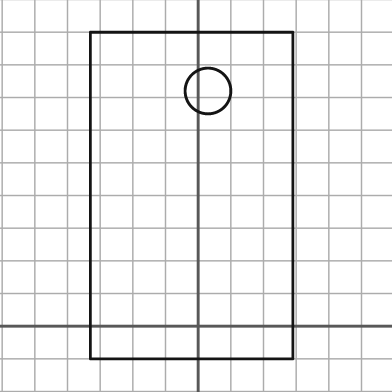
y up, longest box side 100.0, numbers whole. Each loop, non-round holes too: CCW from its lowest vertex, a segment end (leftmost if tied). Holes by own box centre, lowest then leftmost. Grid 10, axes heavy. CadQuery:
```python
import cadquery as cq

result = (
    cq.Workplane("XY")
    .moveTo(-33.0, -10.0)
    .lineTo(29.0, -10.0)
    .lineTo(29.0, 90.0)
    .lineTo(-33.0, 90.0)
    .close()
    .moveTo(3.0, 72.0)
    .circle(7.0)
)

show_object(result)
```